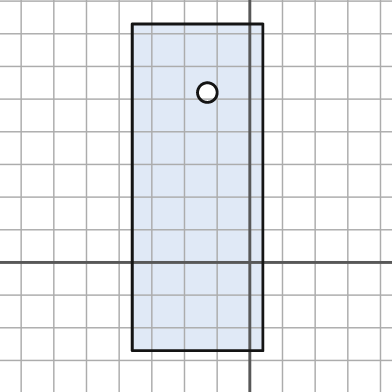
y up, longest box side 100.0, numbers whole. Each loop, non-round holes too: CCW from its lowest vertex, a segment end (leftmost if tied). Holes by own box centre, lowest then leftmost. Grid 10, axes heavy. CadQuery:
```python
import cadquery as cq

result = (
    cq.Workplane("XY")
    .moveTo(-36.0, -27.0)
    .lineTo(4.0, -27.0)
    .lineTo(4.0, 73.0)
    .lineTo(-36.0, 73.0)
    .close()
    .moveTo(-13.0, 52.0)
    .circle(3.0)
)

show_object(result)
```